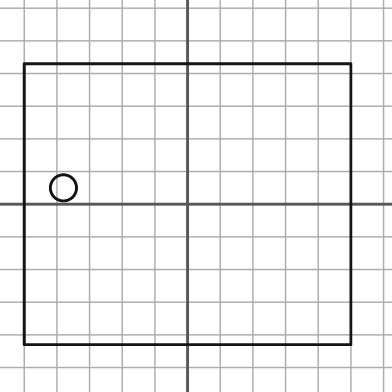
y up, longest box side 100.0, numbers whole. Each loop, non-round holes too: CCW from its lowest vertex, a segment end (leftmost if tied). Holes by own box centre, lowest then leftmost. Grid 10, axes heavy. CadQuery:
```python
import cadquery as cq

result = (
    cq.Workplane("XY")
    .moveTo(-50.0, -43.0)
    .lineTo(50.0, -43.0)
    .lineTo(50.0, 43.0)
    .lineTo(-50.0, 43.0)
    .close()
    .moveTo(-38.0, 5.0)
    .circle(4.0)
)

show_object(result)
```